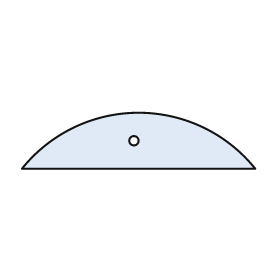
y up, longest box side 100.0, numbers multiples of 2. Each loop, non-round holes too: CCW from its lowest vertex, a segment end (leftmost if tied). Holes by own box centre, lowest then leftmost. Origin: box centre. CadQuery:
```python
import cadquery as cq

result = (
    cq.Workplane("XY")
    .moveTo(-50.0, -12.0)
    .lineTo(50.0, -12.0)
    .threePointArc((0.0, 12.0), (-50.0, -12.0))
    .close()
    .moveTo(-2.0, 0.0)
    .circle(2.0)
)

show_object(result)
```